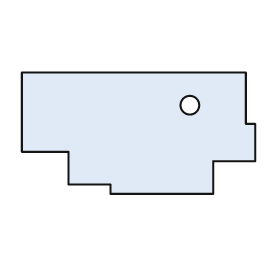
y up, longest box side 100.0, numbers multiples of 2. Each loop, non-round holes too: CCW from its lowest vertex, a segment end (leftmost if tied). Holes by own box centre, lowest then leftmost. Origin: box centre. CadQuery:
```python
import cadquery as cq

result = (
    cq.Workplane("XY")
    .moveTo(-12.0, -26.0)
    .lineTo(32.0, -26.0)
    .lineTo(32.0, -12.0)
    .lineTo(50.0, -12.0)
    .lineTo(50.0, 4.0)
    .lineTo(46.0, 4.0)
    .lineTo(46.0, 26.0)
    .lineTo(-50.0, 26.0)
    .lineTo(-50.0, -8.0)
    .lineTo(-30.0, -8.0)
    .lineTo(-30.0, -22.0)
    .lineTo(-12.0, -22.0)
    .close()
    .moveTo(22.0, 12.0)
    .circle(4.0)
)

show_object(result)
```